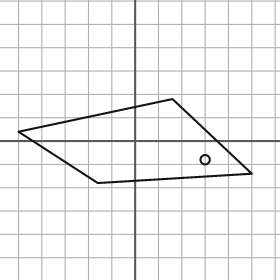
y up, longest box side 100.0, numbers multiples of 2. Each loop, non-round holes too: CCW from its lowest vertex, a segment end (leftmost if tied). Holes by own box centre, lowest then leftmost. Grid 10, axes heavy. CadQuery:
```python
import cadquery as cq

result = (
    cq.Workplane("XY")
    .moveTo(-16.0, -18.0)
    .lineTo(50.0, -14.0)
    .lineTo(16.0, 18.0)
    .lineTo(-50.0, 4.0)
    .close()
    .moveTo(30.0, -8.0)
    .circle(2.0)
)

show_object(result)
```